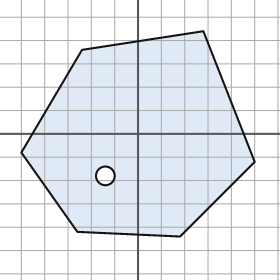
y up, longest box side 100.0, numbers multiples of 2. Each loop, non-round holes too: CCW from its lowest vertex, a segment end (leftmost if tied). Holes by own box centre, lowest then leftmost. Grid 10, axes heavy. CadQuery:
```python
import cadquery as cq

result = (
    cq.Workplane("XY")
    .moveTo(18.0, -44.0)
    .lineTo(50.0, -12.0)
    .lineTo(28.0, 44.0)
    .lineTo(-24.0, 36.0)
    .lineTo(-50.0, -8.0)
    .lineTo(-26.0, -42.0)
    .close()
    .moveTo(-14.0, -18.0)
    .circle(4.0)
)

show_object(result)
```